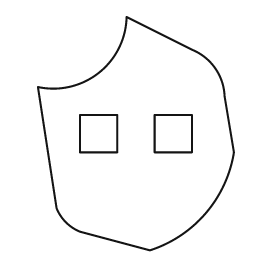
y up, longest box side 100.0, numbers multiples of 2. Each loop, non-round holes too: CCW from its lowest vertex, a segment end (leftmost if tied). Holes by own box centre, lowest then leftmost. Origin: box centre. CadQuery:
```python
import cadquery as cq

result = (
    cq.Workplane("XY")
    .moveTo(6.0, -50.0)
    .threePointArc((30.0, -34.0), (42.0, -8.0))
    .lineTo(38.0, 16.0)
    .threePointArc((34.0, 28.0), (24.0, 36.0))
    .lineTo(-4.0, 50.0)
    .threePointArc((-16.0, 26.0), (-42.0, 20.0))
    .lineTo(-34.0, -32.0)
    .threePointArc((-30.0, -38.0), (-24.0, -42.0))
    .close()
    .moveTo(-24.0, -8.0)
    .lineTo(-8.0, -8.0)
    .lineTo(-8.0, 8.0)
    .lineTo(-24.0, 8.0)
    .close()
    .moveTo(8.0, -8.0)
    .lineTo(24.0, -8.0)
    .lineTo(24.0, 8.0)
    .lineTo(8.0, 8.0)
    .close()
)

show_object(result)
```